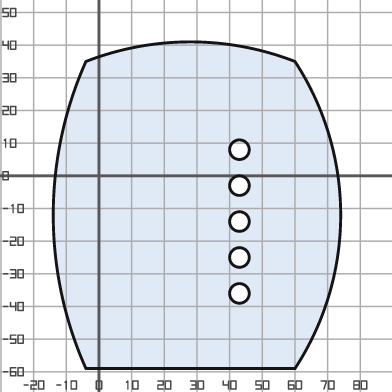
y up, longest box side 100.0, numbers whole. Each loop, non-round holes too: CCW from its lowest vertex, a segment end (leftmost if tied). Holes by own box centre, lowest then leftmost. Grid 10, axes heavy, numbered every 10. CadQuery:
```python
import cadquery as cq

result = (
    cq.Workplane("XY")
    .moveTo(-4.0, -59.0)
    .lineTo(60.0, -59.0)
    .threePointArc((74.0, -12.0), (60.0, 35.0))
    .threePointArc((28.0, 41.0), (-4.0, 35.0))
    .threePointArc((-14.0, -12.0), (-4.0, -59.0))
    .close()
    .moveTo(43.0, -36.0)
    .circle(3.0)
    .moveTo(43.0, -25.0)
    .circle(3.0)
    .moveTo(43.0, -14.0)
    .circle(3.0)
    .moveTo(43.0, -3.0)
    .circle(3.0)
    .moveTo(43.0, 8.0)
    .circle(3.0)
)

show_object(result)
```